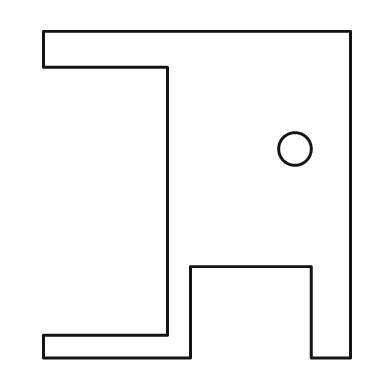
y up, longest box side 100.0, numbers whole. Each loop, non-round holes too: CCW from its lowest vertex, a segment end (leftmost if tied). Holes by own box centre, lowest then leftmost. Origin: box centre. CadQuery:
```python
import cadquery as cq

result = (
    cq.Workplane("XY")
    .moveTo(-47.0, -50.0)
    .lineTo(-2.0, -50.0)
    .lineTo(-2.0, -22.0)
    .lineTo(35.0, -22.0)
    .lineTo(35.0, -50.0)
    .lineTo(47.0, -50.0)
    .lineTo(47.0, 50.0)
    .lineTo(-47.0, 50.0)
    .lineTo(-47.0, 39.0)
    .lineTo(-9.0, 39.0)
    .lineTo(-9.0, -43.0)
    .lineTo(-47.0, -43.0)
    .close()
    .moveTo(30.0, 14.0)
    .circle(5.0)
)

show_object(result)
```